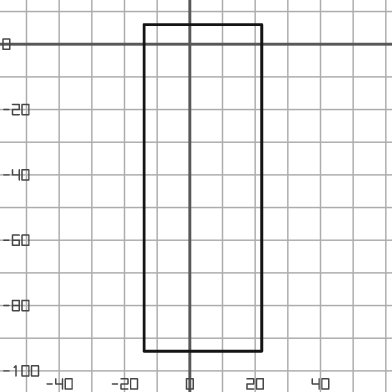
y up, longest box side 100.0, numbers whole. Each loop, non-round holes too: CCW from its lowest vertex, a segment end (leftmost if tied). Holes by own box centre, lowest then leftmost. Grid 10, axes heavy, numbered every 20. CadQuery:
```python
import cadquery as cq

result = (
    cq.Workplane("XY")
    .moveTo(-14.0, -94.0)
    .lineTo(22.0, -94.0)
    .lineTo(22.0, 6.0)
    .lineTo(-14.0, 6.0)
    .close()
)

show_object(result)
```